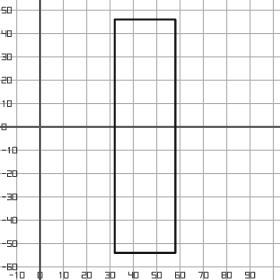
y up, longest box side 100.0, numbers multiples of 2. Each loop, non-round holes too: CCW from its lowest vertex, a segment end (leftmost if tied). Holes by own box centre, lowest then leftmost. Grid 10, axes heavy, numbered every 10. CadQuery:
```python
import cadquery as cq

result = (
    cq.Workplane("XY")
    .moveTo(32.0, -54.0)
    .lineTo(58.0, -54.0)
    .lineTo(58.0, 46.0)
    .lineTo(32.0, 46.0)
    .close()
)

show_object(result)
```